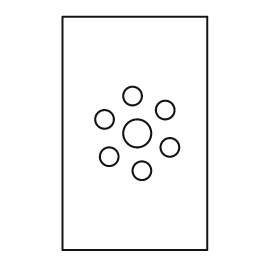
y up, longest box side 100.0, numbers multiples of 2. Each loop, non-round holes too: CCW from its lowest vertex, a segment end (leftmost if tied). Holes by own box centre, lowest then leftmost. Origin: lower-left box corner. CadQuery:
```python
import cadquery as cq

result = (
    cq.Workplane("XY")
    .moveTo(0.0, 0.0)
    .lineTo(62.0, 0.0)
    .lineTo(62.0, 100.0)
    .lineTo(0.0, 100.0)
    .close()
    .moveTo(34.0, 34.0)
    .circle(4.0)
    .moveTo(20.0, 40.0)
    .circle(4.0)
    .moveTo(46.0, 44.0)
    .circle(4.0)
    .moveTo(32.0, 50.0)
    .circle(6.0)
    .moveTo(18.0, 56.0)
    .circle(4.0)
    .moveTo(44.0, 60.0)
    .circle(4.0)
    .moveTo(30.0, 66.0)
    .circle(4.0)
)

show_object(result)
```